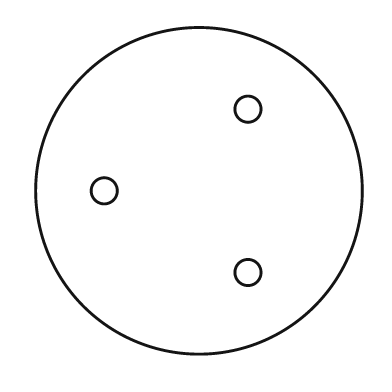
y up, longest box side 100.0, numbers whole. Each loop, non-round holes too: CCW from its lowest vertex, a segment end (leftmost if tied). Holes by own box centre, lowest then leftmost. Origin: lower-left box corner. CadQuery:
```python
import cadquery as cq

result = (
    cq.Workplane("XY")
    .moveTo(50.0, 50.0)
    .circle(50.0)
    .moveTo(65.0, 25.0)
    .circle(4.0)
    .moveTo(21.0, 50.0)
    .circle(4.0)
    .moveTo(65.0, 75.0)
    .circle(4.0)
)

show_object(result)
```